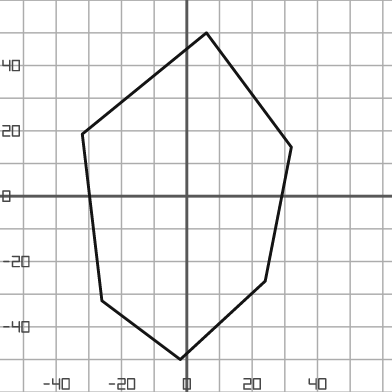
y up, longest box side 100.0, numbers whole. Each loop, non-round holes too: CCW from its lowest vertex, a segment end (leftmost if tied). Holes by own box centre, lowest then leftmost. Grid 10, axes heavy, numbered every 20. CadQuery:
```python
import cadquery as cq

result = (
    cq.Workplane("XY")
    .moveTo(-2.0, -50.0)
    .lineTo(24.0, -26.0)
    .lineTo(32.0, 15.0)
    .lineTo(6.0, 50.0)
    .lineTo(-32.0, 19.0)
    .lineTo(-26.0, -32.0)
    .close()
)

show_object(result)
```